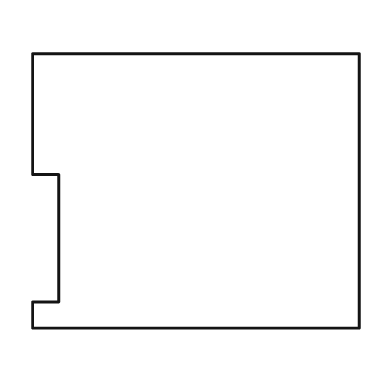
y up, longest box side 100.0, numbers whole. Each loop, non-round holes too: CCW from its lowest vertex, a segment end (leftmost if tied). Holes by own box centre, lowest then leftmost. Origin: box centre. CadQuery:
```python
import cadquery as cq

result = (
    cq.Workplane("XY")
    .moveTo(-50.0, -42.0)
    .lineTo(50.0, -42.0)
    .lineTo(50.0, 42.0)
    .lineTo(-50.0, 42.0)
    .lineTo(-50.0, 5.0)
    .lineTo(-42.0, 5.0)
    .lineTo(-42.0, -34.0)
    .lineTo(-50.0, -34.0)
    .close()
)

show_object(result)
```